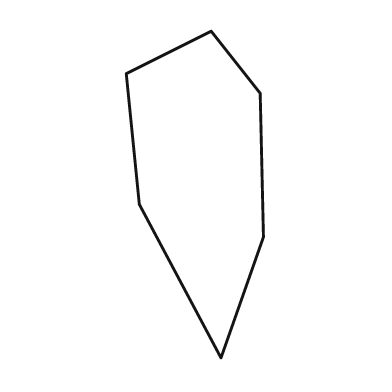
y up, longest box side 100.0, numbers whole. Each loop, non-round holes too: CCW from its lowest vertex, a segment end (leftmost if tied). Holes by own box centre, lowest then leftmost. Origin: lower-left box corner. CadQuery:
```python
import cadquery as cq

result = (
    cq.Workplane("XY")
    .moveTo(29.0, 0.0)
    .lineTo(42.0, 37.0)
    .lineTo(41.0, 81.0)
    .lineTo(26.0, 100.0)
    .lineTo(0.0, 87.0)
    .lineTo(4.0, 47.0)
    .close()
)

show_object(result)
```